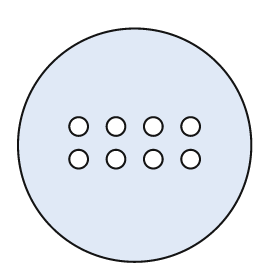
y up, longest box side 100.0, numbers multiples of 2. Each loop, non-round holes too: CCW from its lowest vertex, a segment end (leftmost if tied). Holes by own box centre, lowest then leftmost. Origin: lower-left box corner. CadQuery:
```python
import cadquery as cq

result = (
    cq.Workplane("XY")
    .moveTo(50.0, 50.0)
    .circle(50.0)
    .moveTo(26.0, 44.0)
    .circle(4.0)
    .moveTo(42.0, 44.0)
    .circle(4.0)
    .moveTo(58.0, 44.0)
    .circle(4.0)
    .moveTo(74.0, 44.0)
    .circle(4.0)
    .moveTo(26.0, 58.0)
    .circle(4.0)
    .moveTo(42.0, 58.0)
    .circle(4.0)
    .moveTo(58.0, 58.0)
    .circle(4.0)
    .moveTo(74.0, 58.0)
    .circle(4.0)
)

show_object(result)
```